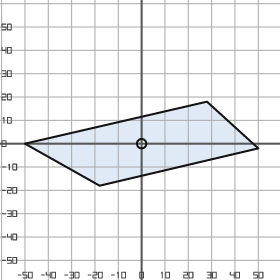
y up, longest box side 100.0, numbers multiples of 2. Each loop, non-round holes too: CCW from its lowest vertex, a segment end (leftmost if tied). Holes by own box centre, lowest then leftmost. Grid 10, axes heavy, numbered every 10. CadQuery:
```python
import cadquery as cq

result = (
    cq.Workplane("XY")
    .moveTo(-18.0, -18.0)
    .lineTo(50.0, -2.0)
    .lineTo(28.0, 18.0)
    .lineTo(-50.0, 0.0)
    .close()
    .moveTo(0.0, 0.0)
    .circle(2.0)
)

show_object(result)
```